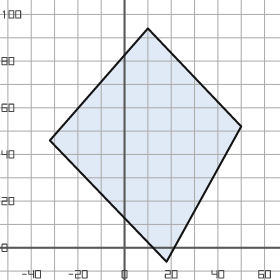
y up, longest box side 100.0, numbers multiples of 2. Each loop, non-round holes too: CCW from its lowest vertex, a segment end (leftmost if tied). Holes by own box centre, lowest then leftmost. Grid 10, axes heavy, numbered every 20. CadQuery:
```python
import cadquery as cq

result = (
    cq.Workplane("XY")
    .moveTo(18.0, -6.0)
    .lineTo(50.0, 52.0)
    .lineTo(10.0, 94.0)
    .lineTo(-32.0, 46.0)
    .close()
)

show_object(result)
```